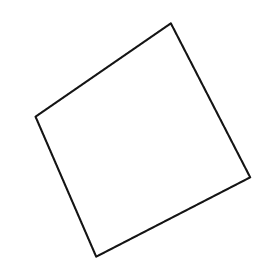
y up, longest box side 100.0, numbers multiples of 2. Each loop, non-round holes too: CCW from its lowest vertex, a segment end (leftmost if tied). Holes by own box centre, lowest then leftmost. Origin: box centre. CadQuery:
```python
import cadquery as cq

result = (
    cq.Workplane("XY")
    .moveTo(-20.0, -50.0)
    .lineTo(46.0, -16.0)
    .lineTo(12.0, 50.0)
    .lineTo(-46.0, 10.0)
    .close()
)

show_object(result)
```